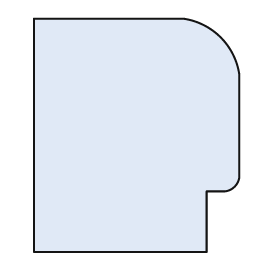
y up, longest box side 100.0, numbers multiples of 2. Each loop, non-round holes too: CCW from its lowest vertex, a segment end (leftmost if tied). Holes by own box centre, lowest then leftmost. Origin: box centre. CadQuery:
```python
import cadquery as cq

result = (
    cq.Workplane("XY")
    .moveTo(-44.0, -50.0)
    .lineTo(30.0, -50.0)
    .lineTo(30.0, -24.0)
    .lineTo(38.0, -24.0)
    .threePointArc((42.0, -22.0), (44.0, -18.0))
    .lineTo(44.0, 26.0)
    .threePointArc((36.0, 42.0), (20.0, 50.0))
    .lineTo(-44.0, 50.0)
    .close()
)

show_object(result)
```